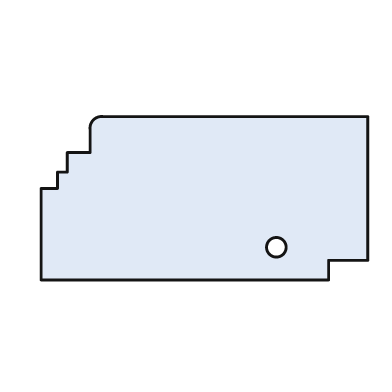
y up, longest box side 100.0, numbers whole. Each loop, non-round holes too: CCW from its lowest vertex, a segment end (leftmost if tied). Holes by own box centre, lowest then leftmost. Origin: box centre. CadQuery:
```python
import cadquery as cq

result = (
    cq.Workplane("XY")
    .moveTo(-50.0, -25.0)
    .lineTo(38.0, -25.0)
    .lineTo(38.0, -19.0)
    .lineTo(50.0, -19.0)
    .lineTo(50.0, 25.0)
    .lineTo(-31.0, 25.0)
    .threePointArc((-34.0, 24.0), (-35.0, 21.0))
    .lineTo(-35.0, 14.0)
    .lineTo(-42.0, 14.0)
    .lineTo(-42.0, 8.0)
    .lineTo(-45.0, 8.0)
    .lineTo(-45.0, 3.0)
    .lineTo(-50.0, 3.0)
    .close()
    .moveTo(22.0, -15.0)
    .circle(3.0)
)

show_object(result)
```